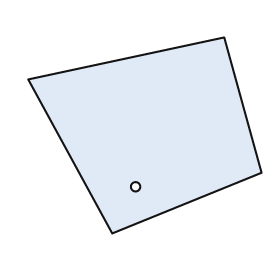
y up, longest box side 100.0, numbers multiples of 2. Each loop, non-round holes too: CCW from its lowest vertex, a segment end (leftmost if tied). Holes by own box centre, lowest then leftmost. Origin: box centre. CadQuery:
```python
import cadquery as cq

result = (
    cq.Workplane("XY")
    .moveTo(-14.0, -42.0)
    .lineTo(50.0, -16.0)
    .lineTo(34.0, 42.0)
    .lineTo(-50.0, 24.0)
    .close()
    .moveTo(-4.0, -22.0)
    .circle(2.0)
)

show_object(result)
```